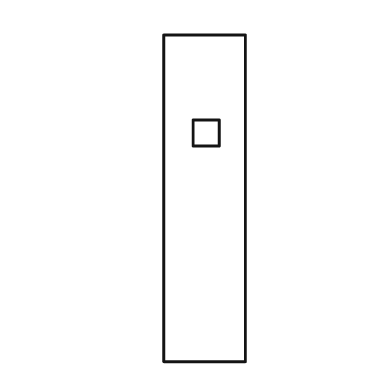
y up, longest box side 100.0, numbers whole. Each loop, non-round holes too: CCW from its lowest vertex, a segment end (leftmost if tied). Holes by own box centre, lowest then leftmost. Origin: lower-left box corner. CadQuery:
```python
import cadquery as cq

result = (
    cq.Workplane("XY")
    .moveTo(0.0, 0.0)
    .lineTo(25.0, 0.0)
    .lineTo(25.0, 100.0)
    .lineTo(0.0, 100.0)
    .close()
    .moveTo(9.0, 66.0)
    .lineTo(17.0, 66.0)
    .lineTo(17.0, 74.0)
    .lineTo(9.0, 74.0)
    .close()
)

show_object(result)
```